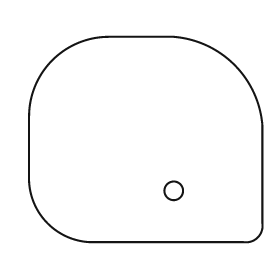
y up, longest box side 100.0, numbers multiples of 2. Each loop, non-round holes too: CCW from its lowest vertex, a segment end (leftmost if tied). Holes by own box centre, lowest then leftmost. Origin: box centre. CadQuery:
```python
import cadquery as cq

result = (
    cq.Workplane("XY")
    .moveTo(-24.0, -44.0)
    .lineTo(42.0, -44.0)
    .threePointArc((48.0, -42.0), (50.0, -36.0))
    .lineTo(50.0, 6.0)
    .threePointArc((38.0, 32.0), (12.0, 44.0))
    .lineTo(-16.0, 44.0)
    .threePointArc((-40.0, 34.0), (-50.0, 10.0))
    .lineTo(-50.0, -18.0)
    .threePointArc((-42.0, -36.0), (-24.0, -44.0))
    .close()
    .moveTo(12.0, -22.0)
    .circle(4.0)
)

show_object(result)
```